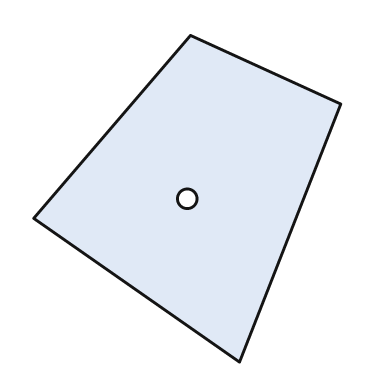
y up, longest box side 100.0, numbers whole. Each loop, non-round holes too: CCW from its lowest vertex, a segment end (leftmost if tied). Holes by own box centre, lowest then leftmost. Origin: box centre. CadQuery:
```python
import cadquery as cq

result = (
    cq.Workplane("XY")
    .moveTo(16.0, -50.0)
    .lineTo(47.0, 29.0)
    .lineTo(1.0, 50.0)
    .lineTo(-47.0, -6.0)
    .close()
    .moveTo(0.0, 0.0)
    .circle(3.0)
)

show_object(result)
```